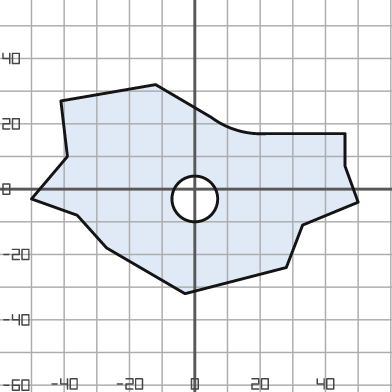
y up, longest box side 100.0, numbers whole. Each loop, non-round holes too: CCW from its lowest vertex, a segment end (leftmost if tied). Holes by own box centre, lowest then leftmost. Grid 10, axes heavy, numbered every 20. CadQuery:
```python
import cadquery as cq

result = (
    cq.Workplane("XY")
    .moveTo(-3.0, -32.0)
    .lineTo(28.0, -24.0)
    .lineTo(33.0, -11.0)
    .lineTo(50.0, -4.0)
    .lineTo(46.0, 7.0)
    .lineTo(46.0, 17.0)
    .lineTo(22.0, 17.0)
    .threePointArc((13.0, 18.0), (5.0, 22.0))
    .lineTo(-12.0, 32.0)
    .lineTo(-41.0, 27.0)
    .lineTo(-39.0, 10.0)
    .lineTo(-50.0, -3.0)
    .lineTo(-36.0, -8.0)
    .lineTo(-27.0, -18.0)
    .close()
    .moveTo(0.0, -3.0)
    .circle(7.0)
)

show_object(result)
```